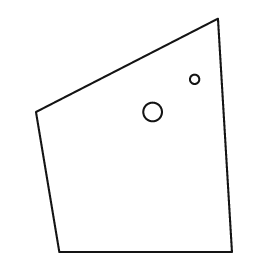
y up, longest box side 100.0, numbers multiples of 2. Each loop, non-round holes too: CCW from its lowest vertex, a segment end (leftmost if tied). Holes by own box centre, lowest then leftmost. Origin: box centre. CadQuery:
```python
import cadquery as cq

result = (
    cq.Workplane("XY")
    .moveTo(-32.0, -50.0)
    .lineTo(42.0, -50.0)
    .lineTo(36.0, 50.0)
    .lineTo(-42.0, 10.0)
    .close()
    .moveTo(8.0, 10.0)
    .circle(4.0)
    .moveTo(26.0, 24.0)
    .circle(2.0)
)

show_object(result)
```